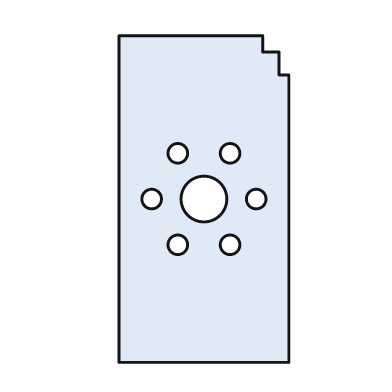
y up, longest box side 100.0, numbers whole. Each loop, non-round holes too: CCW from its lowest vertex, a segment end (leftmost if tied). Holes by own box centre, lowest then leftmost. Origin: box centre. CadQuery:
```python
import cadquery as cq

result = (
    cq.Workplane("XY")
    .moveTo(-26.0, -50.0)
    .lineTo(26.0, -50.0)
    .lineTo(26.0, 38.0)
    .lineTo(23.0, 38.0)
    .lineTo(23.0, 45.0)
    .lineTo(18.0, 45.0)
    .lineTo(18.0, 50.0)
    .lineTo(-26.0, 50.0)
    .close()
    .moveTo(-8.0, -14.0)
    .circle(3.0)
    .moveTo(8.0, -14.0)
    .circle(3.0)
    .moveTo(-16.0, 0.0)
    .circle(3.0)
    .moveTo(0.0, 0.0)
    .circle(7.0)
    .moveTo(16.0, 0.0)
    .circle(3.0)
    .moveTo(-8.0, 14.0)
    .circle(3.0)
    .moveTo(8.0, 14.0)
    .circle(3.0)
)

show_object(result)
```